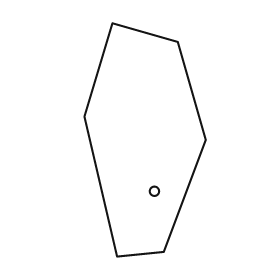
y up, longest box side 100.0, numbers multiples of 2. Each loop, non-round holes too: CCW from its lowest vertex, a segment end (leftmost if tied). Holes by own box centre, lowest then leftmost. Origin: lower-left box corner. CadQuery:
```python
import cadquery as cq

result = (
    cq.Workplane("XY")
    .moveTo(14.0, 0.0)
    .lineTo(34.0, 2.0)
    .lineTo(52.0, 50.0)
    .lineTo(40.0, 92.0)
    .lineTo(12.0, 100.0)
    .lineTo(0.0, 60.0)
    .close()
    .moveTo(30.0, 28.0)
    .circle(2.0)
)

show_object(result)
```